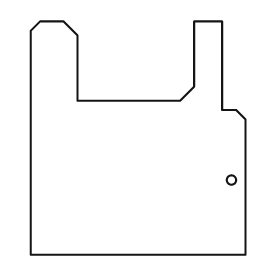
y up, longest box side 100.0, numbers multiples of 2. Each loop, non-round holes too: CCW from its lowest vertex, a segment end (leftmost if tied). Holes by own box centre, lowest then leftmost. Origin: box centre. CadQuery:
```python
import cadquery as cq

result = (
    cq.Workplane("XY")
    .moveTo(-46.0, -50.0)
    .lineTo(46.0, -50.0)
    .lineTo(46.0, 8.0)
    .lineTo(42.0, 12.0)
    .lineTo(36.0, 12.0)
    .lineTo(36.0, 50.0)
    .lineTo(24.0, 50.0)
    .lineTo(24.0, 22.0)
    .lineTo(18.0, 16.0)
    .lineTo(-26.0, 16.0)
    .lineTo(-26.0, 44.0)
    .lineTo(-32.0, 50.0)
    .lineTo(-42.0, 50.0)
    .lineTo(-46.0, 46.0)
    .close()
    .moveTo(40.0, -18.0)
    .circle(2.0)
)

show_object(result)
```